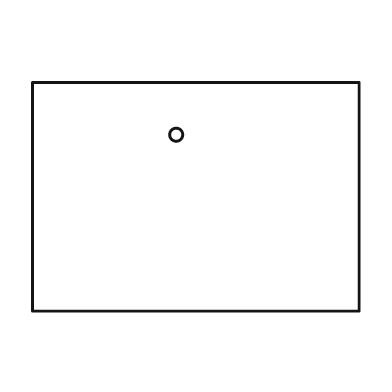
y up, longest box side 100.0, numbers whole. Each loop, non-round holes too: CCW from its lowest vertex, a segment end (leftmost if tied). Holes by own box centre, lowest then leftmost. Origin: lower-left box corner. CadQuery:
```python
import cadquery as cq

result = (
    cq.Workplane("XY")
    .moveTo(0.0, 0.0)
    .lineTo(100.0, 0.0)
    .lineTo(100.0, 70.0)
    .lineTo(0.0, 70.0)
    .close()
    .moveTo(44.0, 54.0)
    .circle(2.0)
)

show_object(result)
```